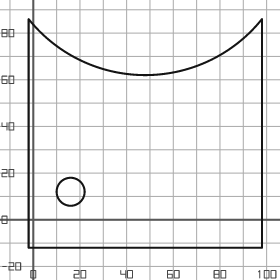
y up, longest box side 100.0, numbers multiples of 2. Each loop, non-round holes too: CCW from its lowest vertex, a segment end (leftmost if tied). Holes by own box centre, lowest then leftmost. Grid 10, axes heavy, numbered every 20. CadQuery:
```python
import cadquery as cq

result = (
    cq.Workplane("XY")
    .moveTo(-2.0, -12.0)
    .lineTo(98.0, -12.0)
    .lineTo(98.0, 86.0)
    .threePointArc((48.0, 62.0), (-2.0, 86.0))
    .close()
    .moveTo(16.0, 12.0)
    .circle(6.0)
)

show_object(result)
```